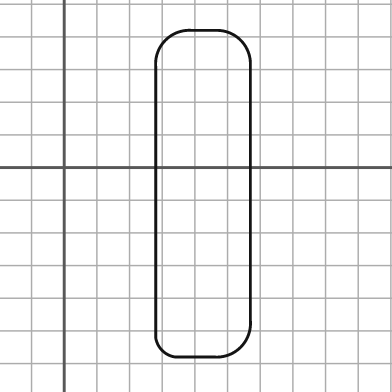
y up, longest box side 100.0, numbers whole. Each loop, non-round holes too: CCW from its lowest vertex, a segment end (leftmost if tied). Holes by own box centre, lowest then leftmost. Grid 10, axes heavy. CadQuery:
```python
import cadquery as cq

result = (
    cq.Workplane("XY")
    .moveTo(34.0, -58.0)
    .lineTo(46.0, -58.0)
    .threePointArc((54.0, -55.0), (57.0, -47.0))
    .lineTo(57.0, 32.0)
    .threePointArc((54.0, 39.0), (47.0, 42.0))
    .lineTo(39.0, 42.0)
    .threePointArc((31.0, 39.0), (28.0, 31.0))
    .lineTo(28.0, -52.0)
    .threePointArc((30.0, -56.0), (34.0, -58.0))
    .close()
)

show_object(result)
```